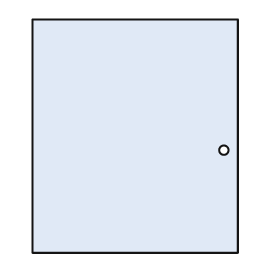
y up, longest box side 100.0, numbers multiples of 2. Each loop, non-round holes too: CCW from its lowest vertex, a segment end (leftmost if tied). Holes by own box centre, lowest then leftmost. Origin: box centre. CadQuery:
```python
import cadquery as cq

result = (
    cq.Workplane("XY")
    .moveTo(-44.0, -50.0)
    .lineTo(44.0, -50.0)
    .lineTo(44.0, 50.0)
    .lineTo(-44.0, 50.0)
    .close()
    .moveTo(38.0, -6.0)
    .circle(2.0)
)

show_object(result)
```